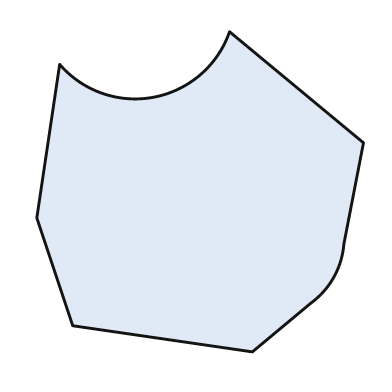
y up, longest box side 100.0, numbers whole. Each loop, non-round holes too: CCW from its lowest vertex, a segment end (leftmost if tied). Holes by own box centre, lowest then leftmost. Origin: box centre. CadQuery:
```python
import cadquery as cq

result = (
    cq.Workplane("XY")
    .moveTo(16.0, -49.0)
    .lineTo(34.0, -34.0)
    .threePointArc((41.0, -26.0), (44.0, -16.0))
    .lineTo(50.0, 15.0)
    .lineTo(9.0, 49.0)
    .threePointArc((-14.0, 29.0), (-43.0, 39.0))
    .lineTo(-50.0, -8.0)
    .lineTo(-39.0, -41.0)
    .close()
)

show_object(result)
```